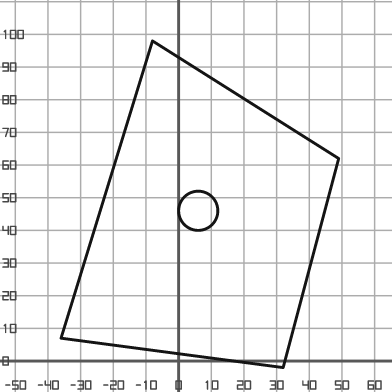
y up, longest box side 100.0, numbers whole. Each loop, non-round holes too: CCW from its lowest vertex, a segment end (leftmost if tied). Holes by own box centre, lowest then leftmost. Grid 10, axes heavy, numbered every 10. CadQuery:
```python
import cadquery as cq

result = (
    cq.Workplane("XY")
    .moveTo(32.0, -2.0)
    .lineTo(49.0, 62.0)
    .lineTo(-8.0, 98.0)
    .lineTo(-36.0, 7.0)
    .close()
    .moveTo(6.0, 46.0)
    .circle(6.0)
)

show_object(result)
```